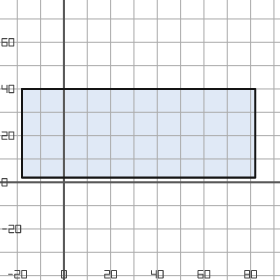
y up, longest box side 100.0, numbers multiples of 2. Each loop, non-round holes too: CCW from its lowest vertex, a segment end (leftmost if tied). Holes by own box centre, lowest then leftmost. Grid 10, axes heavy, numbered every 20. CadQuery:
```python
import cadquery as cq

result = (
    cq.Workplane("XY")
    .moveTo(-18.0, 2.0)
    .lineTo(82.0, 2.0)
    .lineTo(82.0, 40.0)
    .lineTo(-18.0, 40.0)
    .close()
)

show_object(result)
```